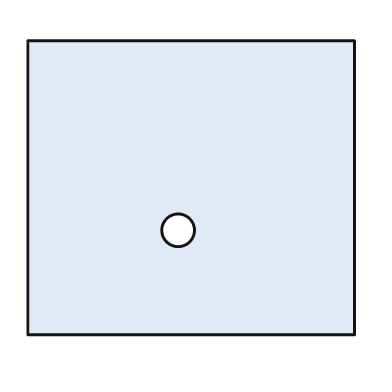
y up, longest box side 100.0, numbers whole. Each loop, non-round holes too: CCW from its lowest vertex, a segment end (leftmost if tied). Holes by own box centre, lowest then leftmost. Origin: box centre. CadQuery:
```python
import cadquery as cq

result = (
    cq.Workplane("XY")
    .moveTo(-50.0, -45.0)
    .lineTo(50.0, -45.0)
    .lineTo(50.0, 45.0)
    .lineTo(-50.0, 45.0)
    .close()
    .moveTo(-4.0, -13.0)
    .circle(5.0)
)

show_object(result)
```